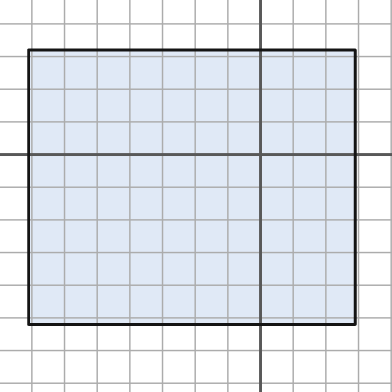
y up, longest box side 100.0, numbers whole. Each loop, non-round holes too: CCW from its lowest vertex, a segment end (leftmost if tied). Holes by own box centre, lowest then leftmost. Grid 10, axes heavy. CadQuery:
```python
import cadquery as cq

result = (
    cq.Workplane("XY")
    .moveTo(-71.0, -52.0)
    .lineTo(29.0, -52.0)
    .lineTo(29.0, 32.0)
    .lineTo(-71.0, 32.0)
    .close()
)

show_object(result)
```